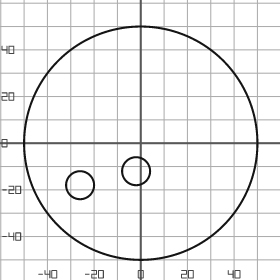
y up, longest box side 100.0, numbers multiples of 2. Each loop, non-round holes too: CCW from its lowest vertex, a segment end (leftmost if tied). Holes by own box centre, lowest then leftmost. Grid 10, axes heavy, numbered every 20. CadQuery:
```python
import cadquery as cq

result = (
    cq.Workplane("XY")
    .moveTo(0.0, 0.0)
    .circle(50.0)
    .moveTo(-26.0, -18.0)
    .circle(6.0)
    .moveTo(-2.0, -12.0)
    .circle(6.0)
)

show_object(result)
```